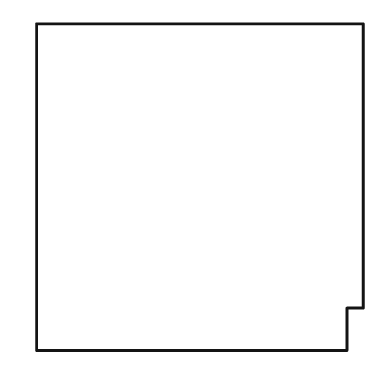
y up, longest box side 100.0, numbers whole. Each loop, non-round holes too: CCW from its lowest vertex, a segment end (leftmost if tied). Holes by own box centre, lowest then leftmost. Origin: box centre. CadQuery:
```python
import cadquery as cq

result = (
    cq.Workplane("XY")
    .moveTo(-50.0, -50.0)
    .lineTo(45.0, -50.0)
    .lineTo(45.0, -37.0)
    .lineTo(50.0, -37.0)
    .lineTo(50.0, 50.0)
    .lineTo(-50.0, 50.0)
    .close()
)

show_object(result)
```